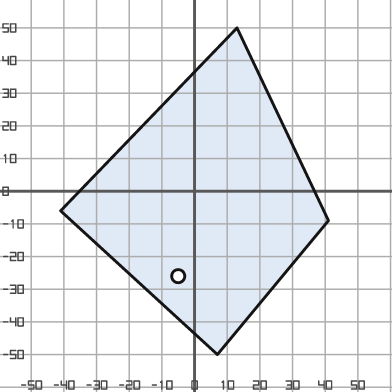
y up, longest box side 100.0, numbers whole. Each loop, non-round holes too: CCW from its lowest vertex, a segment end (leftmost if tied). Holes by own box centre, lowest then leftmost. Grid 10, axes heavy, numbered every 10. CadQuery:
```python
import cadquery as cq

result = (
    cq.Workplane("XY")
    .moveTo(7.0, -50.0)
    .lineTo(41.0, -9.0)
    .lineTo(13.0, 50.0)
    .lineTo(-41.0, -6.0)
    .close()
    .moveTo(-5.0, -26.0)
    .circle(2.0)
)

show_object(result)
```